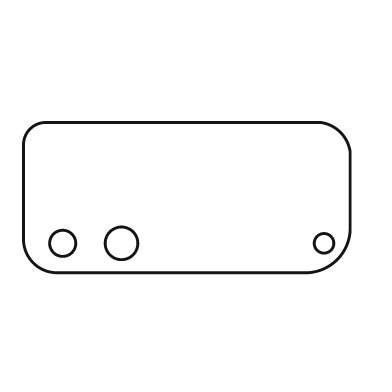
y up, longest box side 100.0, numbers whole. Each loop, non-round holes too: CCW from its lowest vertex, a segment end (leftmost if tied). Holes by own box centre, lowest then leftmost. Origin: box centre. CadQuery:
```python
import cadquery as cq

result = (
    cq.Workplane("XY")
    .moveTo(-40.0, -23.0)
    .lineTo(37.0, -23.0)
    .threePointArc((46.0, -19.0), (50.0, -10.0))
    .lineTo(50.0, 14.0)
    .threePointArc((47.0, 20.0), (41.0, 23.0))
    .lineTo(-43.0, 23.0)
    .threePointArc((-48.0, 21.0), (-50.0, 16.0))
    .lineTo(-50.0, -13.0)
    .threePointArc((-47.0, -20.0), (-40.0, -23.0))
    .close()
    .moveTo(-38.0, -14.0)
    .circle(4.0)
    .moveTo(-20.0, -14.0)
    .circle(5.0)
    .moveTo(42.0, -14.0)
    .circle(3.0)
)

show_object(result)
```